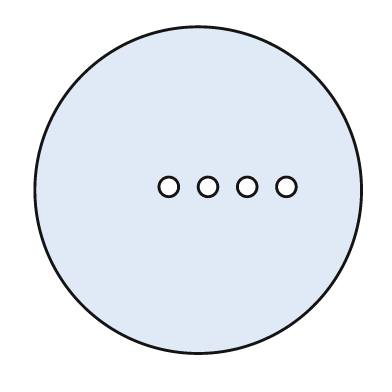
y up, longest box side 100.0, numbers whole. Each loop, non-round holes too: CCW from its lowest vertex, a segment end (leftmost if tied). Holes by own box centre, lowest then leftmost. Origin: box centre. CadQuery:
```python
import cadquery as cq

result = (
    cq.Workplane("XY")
    .moveTo(0.0, 0.0)
    .circle(50.0)
    .moveTo(-9.0, 1.0)
    .circle(3.0)
    .moveTo(3.0, 1.0)
    .circle(3.0)
    .moveTo(15.0, 1.0)
    .circle(3.0)
    .moveTo(27.0, 1.0)
    .circle(3.0)
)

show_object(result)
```